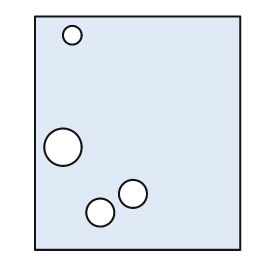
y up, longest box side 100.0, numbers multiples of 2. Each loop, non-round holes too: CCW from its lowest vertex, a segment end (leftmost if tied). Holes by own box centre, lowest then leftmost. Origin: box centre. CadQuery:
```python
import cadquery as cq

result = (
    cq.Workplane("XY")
    .moveTo(-44.0, -50.0)
    .lineTo(44.0, -50.0)
    .lineTo(44.0, 50.0)
    .lineTo(-44.0, 50.0)
    .close()
    .moveTo(-16.0, -34.0)
    .circle(6.0)
    .moveTo(-2.0, -26.0)
    .circle(6.0)
    .moveTo(-32.0, -6.0)
    .circle(8.0)
    .moveTo(-28.0, 42.0)
    .circle(4.0)
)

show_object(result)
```